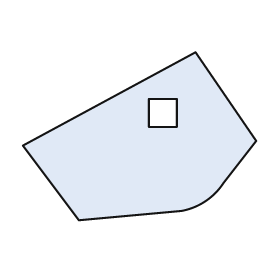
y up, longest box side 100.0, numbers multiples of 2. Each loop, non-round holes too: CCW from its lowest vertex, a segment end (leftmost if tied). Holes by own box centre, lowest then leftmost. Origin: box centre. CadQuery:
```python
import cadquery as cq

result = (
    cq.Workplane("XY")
    .moveTo(-26.0, -36.0)
    .lineTo(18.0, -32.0)
    .threePointArc((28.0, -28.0), (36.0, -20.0))
    .lineTo(50.0, -2.0)
    .lineTo(24.0, 36.0)
    .lineTo(-50.0, -4.0)
    .close()
    .moveTo(4.0, 4.0)
    .lineTo(16.0, 4.0)
    .lineTo(16.0, 16.0)
    .lineTo(4.0, 16.0)
    .close()
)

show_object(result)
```